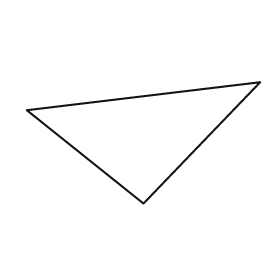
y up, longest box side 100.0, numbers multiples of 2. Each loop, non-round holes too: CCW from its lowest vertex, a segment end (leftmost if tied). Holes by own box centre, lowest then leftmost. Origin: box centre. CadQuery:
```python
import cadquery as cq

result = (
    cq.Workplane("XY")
    .moveTo(0.0, -26.0)
    .lineTo(50.0, 26.0)
    .lineTo(-50.0, 14.0)
    .close()
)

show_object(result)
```